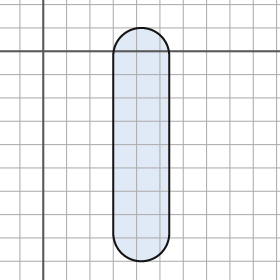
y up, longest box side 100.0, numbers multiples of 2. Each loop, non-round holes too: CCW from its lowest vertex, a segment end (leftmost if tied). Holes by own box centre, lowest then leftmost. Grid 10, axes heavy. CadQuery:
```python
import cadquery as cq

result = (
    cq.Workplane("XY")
    .moveTo(30.0, -78.0)
    .threePointArc((42.0, -90.0), (54.0, -78.0))
    .lineTo(54.0, -2.0)
    .threePointArc((42.0, 10.0), (30.0, -2.0))
    .close()
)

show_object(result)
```